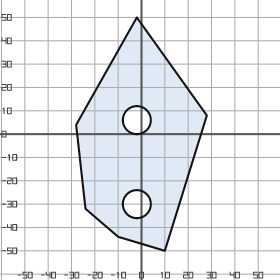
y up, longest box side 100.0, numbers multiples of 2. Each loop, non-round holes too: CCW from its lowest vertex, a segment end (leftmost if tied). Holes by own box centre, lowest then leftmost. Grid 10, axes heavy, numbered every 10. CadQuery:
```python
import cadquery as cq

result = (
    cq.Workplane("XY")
    .moveTo(10.0, -50.0)
    .lineTo(28.0, 8.0)
    .lineTo(-2.0, 50.0)
    .lineTo(-28.0, 4.0)
    .lineTo(-24.0, -32.0)
    .lineTo(-10.0, -44.0)
    .close()
    .moveTo(-2.0, -30.0)
    .circle(6.0)
    .moveTo(-2.0, 6.0)
    .circle(6.0)
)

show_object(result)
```